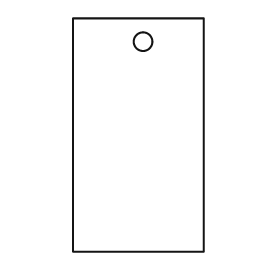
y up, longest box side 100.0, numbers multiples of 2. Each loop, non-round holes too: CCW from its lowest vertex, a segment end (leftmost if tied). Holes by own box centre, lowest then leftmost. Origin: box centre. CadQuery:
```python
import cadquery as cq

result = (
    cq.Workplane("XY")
    .moveTo(-28.0, -50.0)
    .lineTo(28.0, -50.0)
    .lineTo(28.0, 50.0)
    .lineTo(-28.0, 50.0)
    .close()
    .moveTo(2.0, 40.0)
    .circle(4.0)
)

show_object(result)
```